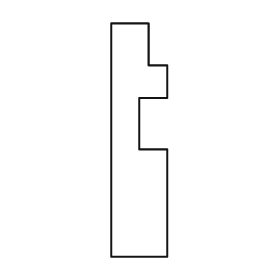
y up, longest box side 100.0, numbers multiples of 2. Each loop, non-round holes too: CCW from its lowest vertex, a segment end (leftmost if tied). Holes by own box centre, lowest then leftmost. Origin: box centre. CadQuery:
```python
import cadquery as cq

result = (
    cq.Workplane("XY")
    .moveTo(-12.0, -50.0)
    .lineTo(12.0, -50.0)
    .lineTo(12.0, -4.0)
    .lineTo(0.0, -4.0)
    .lineTo(0.0, 18.0)
    .lineTo(12.0, 18.0)
    .lineTo(12.0, 32.0)
    .lineTo(4.0, 32.0)
    .lineTo(4.0, 50.0)
    .lineTo(-12.0, 50.0)
    .close()
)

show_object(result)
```